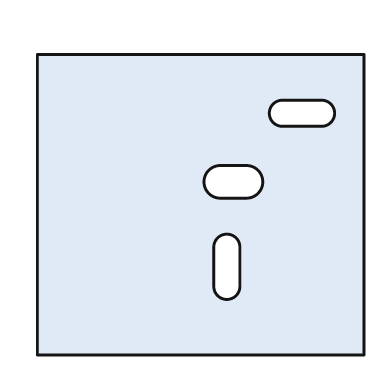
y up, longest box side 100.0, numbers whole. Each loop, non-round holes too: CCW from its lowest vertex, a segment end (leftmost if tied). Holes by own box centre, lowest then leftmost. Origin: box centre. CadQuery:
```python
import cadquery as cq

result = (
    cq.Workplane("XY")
    .moveTo(-50.0, -46.0)
    .lineTo(50.0, -46.0)
    .lineTo(50.0, 46.0)
    .lineTo(-50.0, 46.0)
    .close()
    .moveTo(4.0, -25.0)
    .threePointArc((8.0, -29.0), (12.0, -25.0))
    .lineTo(12.0, -13.0)
    .threePointArc((8.0, -9.0), (4.0, -13.0))
    .close()
    .moveTo(6.0, 2.0)
    .lineTo(14.0, 2.0)
    .threePointArc((19.0, 7.0), (14.0, 12.0))
    .lineTo(6.0, 12.0)
    .threePointArc((1.0, 7.0), (6.0, 2.0))
    .close()
    .moveTo(25.0, 24.0)
    .lineTo(37.0, 24.0)
    .threePointArc((41.0, 28.0), (37.0, 32.0))
    .lineTo(25.0, 32.0)
    .threePointArc((21.0, 28.0), (25.0, 24.0))
    .close()
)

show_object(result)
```